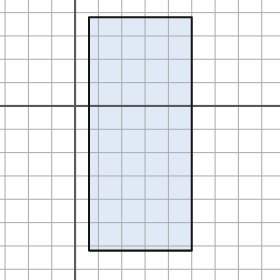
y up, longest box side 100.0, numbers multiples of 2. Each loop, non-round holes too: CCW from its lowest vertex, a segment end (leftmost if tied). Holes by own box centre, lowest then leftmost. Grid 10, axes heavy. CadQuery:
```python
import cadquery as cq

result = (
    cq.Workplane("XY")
    .moveTo(6.0, -62.0)
    .lineTo(50.0, -62.0)
    .lineTo(50.0, 38.0)
    .lineTo(6.0, 38.0)
    .close()
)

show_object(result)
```